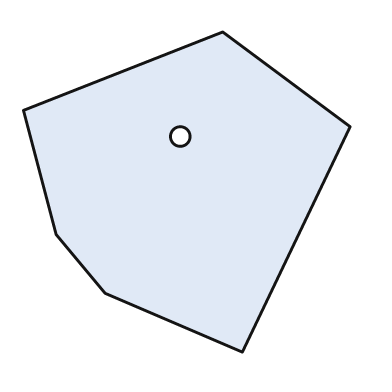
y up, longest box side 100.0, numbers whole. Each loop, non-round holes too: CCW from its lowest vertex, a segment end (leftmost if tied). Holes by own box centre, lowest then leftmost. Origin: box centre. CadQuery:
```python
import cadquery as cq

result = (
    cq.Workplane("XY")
    .moveTo(17.0, -49.0)
    .lineTo(50.0, 20.0)
    .lineTo(11.0, 49.0)
    .lineTo(-50.0, 25.0)
    .lineTo(-40.0, -13.0)
    .lineTo(-25.0, -31.0)
    .close()
    .moveTo(-2.0, 17.0)
    .circle(3.0)
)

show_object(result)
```